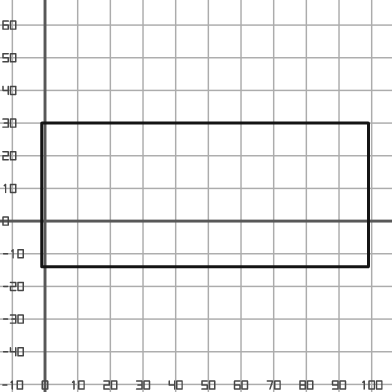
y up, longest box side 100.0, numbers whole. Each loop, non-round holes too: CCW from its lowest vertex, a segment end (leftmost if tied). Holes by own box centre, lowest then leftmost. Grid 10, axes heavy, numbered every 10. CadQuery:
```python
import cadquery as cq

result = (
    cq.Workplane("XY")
    .moveTo(-1.0, -14.0)
    .lineTo(99.0, -14.0)
    .lineTo(99.0, 30.0)
    .lineTo(-1.0, 30.0)
    .close()
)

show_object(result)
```